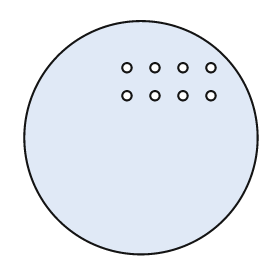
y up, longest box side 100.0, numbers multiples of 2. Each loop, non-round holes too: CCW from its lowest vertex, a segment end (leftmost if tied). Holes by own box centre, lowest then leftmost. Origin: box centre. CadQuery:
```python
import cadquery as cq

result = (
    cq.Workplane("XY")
    .moveTo(0.0, 0.0)
    .circle(50.0)
    .moveTo(-6.0, 18.0)
    .circle(2.0)
    .moveTo(6.0, 18.0)
    .circle(2.0)
    .moveTo(18.0, 18.0)
    .circle(2.0)
    .moveTo(30.0, 18.0)
    .circle(2.0)
    .moveTo(-6.0, 30.0)
    .circle(2.0)
    .moveTo(6.0, 30.0)
    .circle(2.0)
    .moveTo(18.0, 30.0)
    .circle(2.0)
    .moveTo(30.0, 30.0)
    .circle(2.0)
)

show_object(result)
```